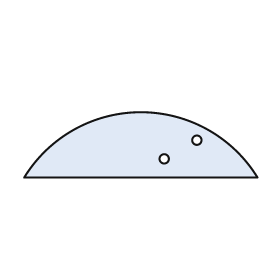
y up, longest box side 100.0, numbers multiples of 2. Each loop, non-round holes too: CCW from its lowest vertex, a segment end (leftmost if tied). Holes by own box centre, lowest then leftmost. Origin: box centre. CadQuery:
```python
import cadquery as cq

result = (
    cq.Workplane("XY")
    .moveTo(-50.0, -14.0)
    .lineTo(50.0, -14.0)
    .threePointArc((0.0, 14.0), (-50.0, -14.0))
    .close()
    .moveTo(10.0, -6.0)
    .circle(2.0)
    .moveTo(24.0, 2.0)
    .circle(2.0)
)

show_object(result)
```